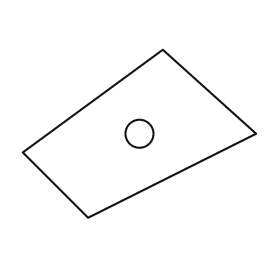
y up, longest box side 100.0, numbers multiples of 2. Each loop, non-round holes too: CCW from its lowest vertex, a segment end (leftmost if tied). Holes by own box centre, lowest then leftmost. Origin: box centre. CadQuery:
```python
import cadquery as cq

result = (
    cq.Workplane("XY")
    .moveTo(-22.0, -36.0)
    .lineTo(50.0, 0.0)
    .lineTo(10.0, 36.0)
    .lineTo(-50.0, -8.0)
    .close()
    .moveTo(0.0, 0.0)
    .circle(6.0)
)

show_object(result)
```